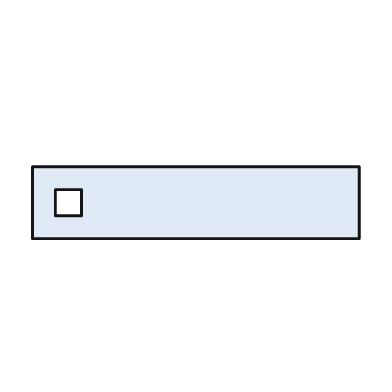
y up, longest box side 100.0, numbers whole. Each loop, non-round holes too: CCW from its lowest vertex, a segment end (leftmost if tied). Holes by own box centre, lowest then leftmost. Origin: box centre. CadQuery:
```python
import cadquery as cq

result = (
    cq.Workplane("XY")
    .moveTo(-50.0, -11.0)
    .lineTo(50.0, -11.0)
    .lineTo(50.0, 11.0)
    .lineTo(-50.0, 11.0)
    .close()
    .moveTo(-43.0, -4.0)
    .lineTo(-35.0, -4.0)
    .lineTo(-35.0, 4.0)
    .lineTo(-43.0, 4.0)
    .close()
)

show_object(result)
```